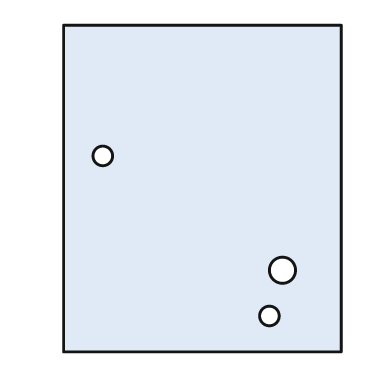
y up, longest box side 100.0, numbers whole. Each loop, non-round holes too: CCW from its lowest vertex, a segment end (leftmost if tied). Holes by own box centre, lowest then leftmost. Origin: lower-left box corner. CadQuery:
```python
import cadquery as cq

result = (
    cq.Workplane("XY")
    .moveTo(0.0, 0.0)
    .lineTo(85.0, 0.0)
    .lineTo(85.0, 100.0)
    .lineTo(0.0, 100.0)
    .close()
    .moveTo(63.0, 11.0)
    .circle(3.0)
    .moveTo(67.0, 25.0)
    .circle(4.0)
    .moveTo(12.0, 60.0)
    .circle(3.0)
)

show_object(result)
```